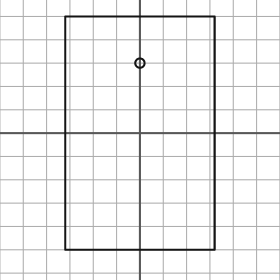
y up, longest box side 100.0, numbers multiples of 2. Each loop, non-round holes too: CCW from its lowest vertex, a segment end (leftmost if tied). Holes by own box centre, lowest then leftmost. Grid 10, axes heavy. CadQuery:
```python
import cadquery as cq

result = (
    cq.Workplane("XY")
    .moveTo(-32.0, -50.0)
    .lineTo(32.0, -50.0)
    .lineTo(32.0, 50.0)
    .lineTo(-32.0, 50.0)
    .close()
    .moveTo(0.0, 30.0)
    .circle(2.0)
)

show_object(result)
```